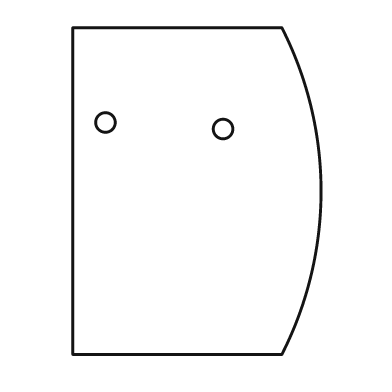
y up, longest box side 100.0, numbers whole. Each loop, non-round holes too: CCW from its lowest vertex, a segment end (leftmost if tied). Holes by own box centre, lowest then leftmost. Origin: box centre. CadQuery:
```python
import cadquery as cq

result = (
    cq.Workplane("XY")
    .moveTo(-38.0, -50.0)
    .lineTo(26.0, -50.0)
    .threePointArc((38.0, 0.0), (26.0, 50.0))
    .lineTo(-38.0, 50.0)
    .close()
    .moveTo(8.0, 19.0)
    .circle(3.0)
    .moveTo(-28.0, 21.0)
    .circle(3.0)
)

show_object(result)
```